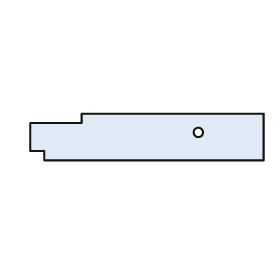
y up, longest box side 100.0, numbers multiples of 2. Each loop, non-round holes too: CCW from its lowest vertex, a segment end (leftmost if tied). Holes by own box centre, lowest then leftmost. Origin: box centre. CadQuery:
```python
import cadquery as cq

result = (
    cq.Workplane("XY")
    .moveTo(-44.0, -10.0)
    .lineTo(50.0, -10.0)
    .lineTo(50.0, 10.0)
    .lineTo(-28.0, 10.0)
    .lineTo(-28.0, 6.0)
    .lineTo(-50.0, 6.0)
    .lineTo(-50.0, -6.0)
    .lineTo(-44.0, -6.0)
    .close()
    .moveTo(22.0, 2.0)
    .circle(2.0)
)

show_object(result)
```